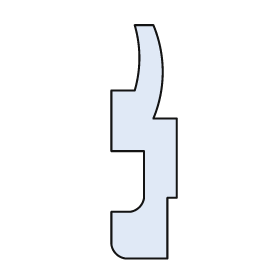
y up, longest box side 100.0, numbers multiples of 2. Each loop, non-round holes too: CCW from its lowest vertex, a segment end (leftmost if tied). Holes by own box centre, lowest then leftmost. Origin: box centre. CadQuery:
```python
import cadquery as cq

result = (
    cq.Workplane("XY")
    .moveTo(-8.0, -50.0)
    .lineTo(10.0, -50.0)
    .lineTo(10.0, -24.0)
    .lineTo(14.0, -24.0)
    .lineTo(14.0, 10.0)
    .lineTo(4.0, 10.0)
    .threePointArc((8.0, 30.0), (4.0, 50.0))
    .lineTo(-4.0, 50.0)
    .threePointArc((-2.0, 36.0), (-4.0, 22.0))
    .lineTo(-14.0, 22.0)
    .lineTo(-14.0, -4.0)
    .lineTo(0.0, -4.0)
    .lineTo(0.0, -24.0)
    .threePointArc((-2.0, -28.0), (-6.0, -30.0))
    .lineTo(-14.0, -30.0)
    .lineTo(-14.0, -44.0)
    .threePointArc((-12.0, -48.0), (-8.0, -50.0))
    .close()
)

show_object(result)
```